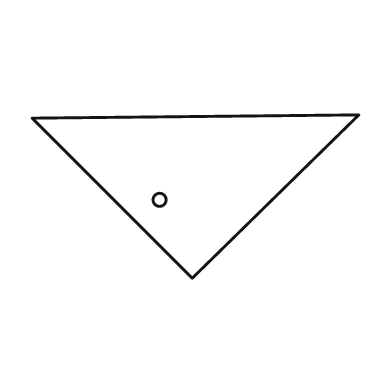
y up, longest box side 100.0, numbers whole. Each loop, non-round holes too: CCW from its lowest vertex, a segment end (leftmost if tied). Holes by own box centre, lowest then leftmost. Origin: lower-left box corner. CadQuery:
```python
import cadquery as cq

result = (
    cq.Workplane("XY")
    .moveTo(49.0, 0.0)
    .lineTo(100.0, 50.0)
    .lineTo(0.0, 49.0)
    .close()
    .moveTo(39.0, 24.0)
    .circle(2.0)
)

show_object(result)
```